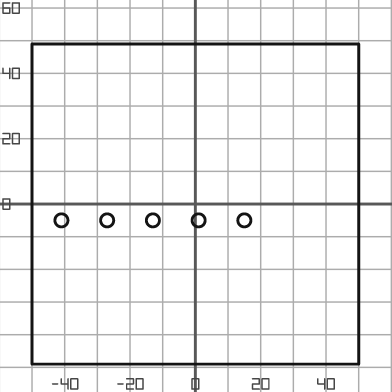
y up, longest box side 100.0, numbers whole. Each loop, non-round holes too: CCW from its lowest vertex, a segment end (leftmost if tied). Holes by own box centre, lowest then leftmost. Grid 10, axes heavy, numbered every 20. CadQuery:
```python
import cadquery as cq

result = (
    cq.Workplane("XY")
    .moveTo(-50.0, -49.0)
    .lineTo(50.0, -49.0)
    .lineTo(50.0, 49.0)
    .lineTo(-50.0, 49.0)
    .close()
    .moveTo(-41.0, -5.0)
    .circle(2.0)
    .moveTo(-27.0, -5.0)
    .circle(2.0)
    .moveTo(-13.0, -5.0)
    .circle(2.0)
    .moveTo(1.0, -5.0)
    .circle(2.0)
    .moveTo(15.0, -5.0)
    .circle(2.0)
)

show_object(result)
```